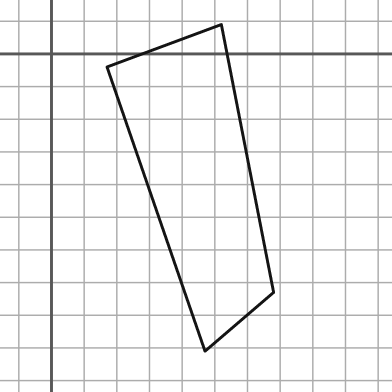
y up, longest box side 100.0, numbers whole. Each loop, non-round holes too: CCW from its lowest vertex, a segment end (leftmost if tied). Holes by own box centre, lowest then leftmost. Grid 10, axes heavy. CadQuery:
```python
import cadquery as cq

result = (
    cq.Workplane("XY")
    .moveTo(47.0, -91.0)
    .lineTo(68.0, -73.0)
    .lineTo(52.0, 9.0)
    .lineTo(17.0, -4.0)
    .close()
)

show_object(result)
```